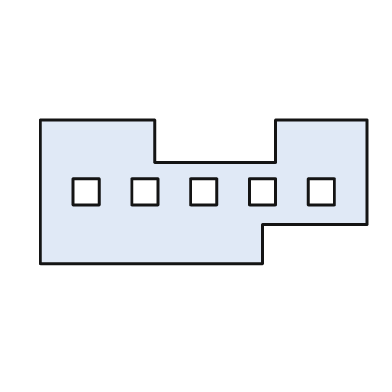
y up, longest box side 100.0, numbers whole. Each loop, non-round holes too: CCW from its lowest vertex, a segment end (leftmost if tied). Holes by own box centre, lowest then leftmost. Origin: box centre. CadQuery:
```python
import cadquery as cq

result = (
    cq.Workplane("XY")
    .moveTo(-50.0, -22.0)
    .lineTo(18.0, -22.0)
    .lineTo(18.0, -10.0)
    .lineTo(50.0, -10.0)
    .lineTo(50.0, 22.0)
    .lineTo(22.0, 22.0)
    .lineTo(22.0, 9.0)
    .lineTo(-15.0, 9.0)
    .lineTo(-15.0, 22.0)
    .lineTo(-50.0, 22.0)
    .close()
    .moveTo(-40.0, -4.0)
    .lineTo(-32.0, -4.0)
    .lineTo(-32.0, 4.0)
    .lineTo(-40.0, 4.0)
    .close()
    .moveTo(-22.0, -4.0)
    .lineTo(-14.0, -4.0)
    .lineTo(-14.0, 4.0)
    .lineTo(-22.0, 4.0)
    .close()
    .moveTo(-4.0, -4.0)
    .lineTo(4.0, -4.0)
    .lineTo(4.0, 4.0)
    .lineTo(-4.0, 4.0)
    .close()
    .moveTo(14.0, -4.0)
    .lineTo(22.0, -4.0)
    .lineTo(22.0, 4.0)
    .lineTo(14.0, 4.0)
    .close()
    .moveTo(32.0, -4.0)
    .lineTo(40.0, -4.0)
    .lineTo(40.0, 4.0)
    .lineTo(32.0, 4.0)
    .close()
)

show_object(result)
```